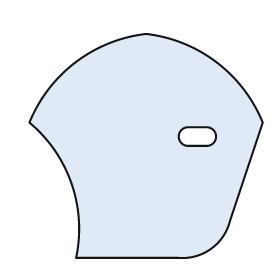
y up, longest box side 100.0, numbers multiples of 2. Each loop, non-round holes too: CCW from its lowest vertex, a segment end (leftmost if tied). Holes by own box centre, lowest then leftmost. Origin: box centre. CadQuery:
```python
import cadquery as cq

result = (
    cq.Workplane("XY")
    .moveTo(-30.0, -48.0)
    .lineTo(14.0, -48.0)
    .threePointArc((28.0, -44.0), (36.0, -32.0))
    .lineTo(50.0, 10.0)
    .threePointArc((30.0, 36.0), (0.0, 48.0))
    .threePointArc((-30.0, 36.0), (-50.0, 10.0))
    .threePointArc((-32.0, -16.0), (-30.0, -48.0))
    .close()
    .moveTo(18.0, 0.0)
    .lineTo(26.0, 0.0)
    .threePointArc((30.0, 4.0), (26.0, 8.0))
    .lineTo(18.0, 8.0)
    .threePointArc((14.0, 4.0), (18.0, 0.0))
    .close()
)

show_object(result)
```